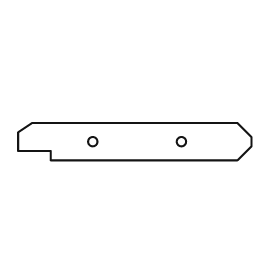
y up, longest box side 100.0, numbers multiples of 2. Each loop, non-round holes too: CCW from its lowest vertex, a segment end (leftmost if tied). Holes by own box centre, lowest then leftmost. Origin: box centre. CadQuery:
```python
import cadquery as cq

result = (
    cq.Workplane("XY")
    .moveTo(-36.0, -8.0)
    .lineTo(44.0, -8.0)
    .lineTo(50.0, -2.0)
    .lineTo(50.0, 2.0)
    .lineTo(44.0, 8.0)
    .lineTo(-44.0, 8.0)
    .lineTo(-50.0, 4.0)
    .lineTo(-50.0, -4.0)
    .lineTo(-36.0, -4.0)
    .close()
    .moveTo(-18.0, 0.0)
    .circle(2.0)
    .moveTo(20.0, 0.0)
    .circle(2.0)
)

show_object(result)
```